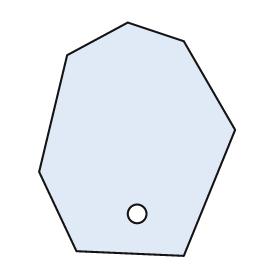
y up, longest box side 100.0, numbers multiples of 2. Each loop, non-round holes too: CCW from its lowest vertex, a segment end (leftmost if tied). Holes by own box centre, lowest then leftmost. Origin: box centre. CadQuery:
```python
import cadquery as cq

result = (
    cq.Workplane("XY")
    .moveTo(20.0, -50.0)
    .lineTo(42.0, 4.0)
    .lineTo(20.0, 42.0)
    .lineTo(-4.0, 50.0)
    .lineTo(-30.0, 36.0)
    .lineTo(-42.0, -14.0)
    .lineTo(-26.0, -48.0)
    .close()
    .moveTo(0.0, -32.0)
    .circle(4.0)
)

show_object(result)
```